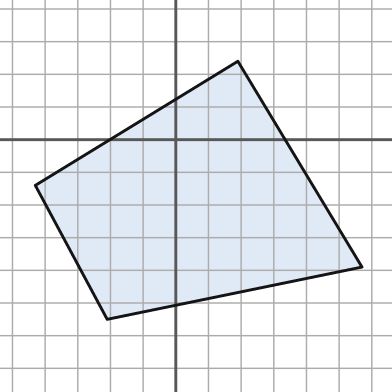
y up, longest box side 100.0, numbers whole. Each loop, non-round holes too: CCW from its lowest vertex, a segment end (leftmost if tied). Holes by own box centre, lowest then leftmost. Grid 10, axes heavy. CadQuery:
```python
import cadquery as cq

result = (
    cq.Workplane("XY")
    .moveTo(-21.0, -55.0)
    .lineTo(57.0, -39.0)
    .lineTo(19.0, 24.0)
    .lineTo(-43.0, -14.0)
    .close()
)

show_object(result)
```